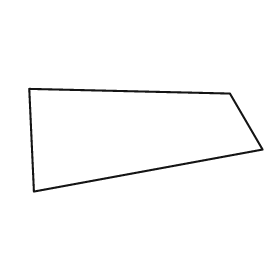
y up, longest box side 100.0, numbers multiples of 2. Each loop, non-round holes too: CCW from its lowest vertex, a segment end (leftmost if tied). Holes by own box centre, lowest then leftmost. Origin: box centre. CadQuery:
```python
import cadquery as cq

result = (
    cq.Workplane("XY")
    .moveTo(-48.0, -22.0)
    .lineTo(50.0, -4.0)
    .lineTo(36.0, 20.0)
    .lineTo(-50.0, 22.0)
    .close()
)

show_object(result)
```